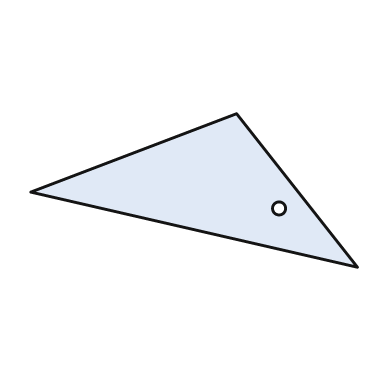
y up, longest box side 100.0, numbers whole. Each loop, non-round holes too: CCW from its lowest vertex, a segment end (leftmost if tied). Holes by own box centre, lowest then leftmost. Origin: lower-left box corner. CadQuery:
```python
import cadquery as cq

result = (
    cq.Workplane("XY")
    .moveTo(100.0, 0.0)
    .lineTo(63.0, 47.0)
    .lineTo(0.0, 23.0)
    .close()
    .moveTo(76.0, 18.0)
    .circle(2.0)
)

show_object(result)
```